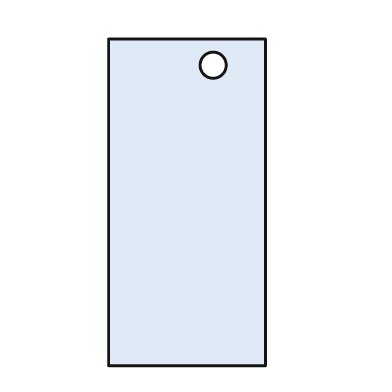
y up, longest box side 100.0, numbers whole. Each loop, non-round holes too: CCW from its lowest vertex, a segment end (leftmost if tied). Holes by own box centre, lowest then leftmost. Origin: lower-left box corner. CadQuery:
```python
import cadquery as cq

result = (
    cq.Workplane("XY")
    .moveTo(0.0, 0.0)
    .lineTo(48.0, 0.0)
    .lineTo(48.0, 100.0)
    .lineTo(0.0, 100.0)
    .close()
    .moveTo(32.0, 92.0)
    .circle(4.0)
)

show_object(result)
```